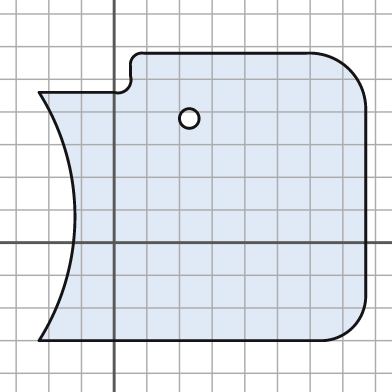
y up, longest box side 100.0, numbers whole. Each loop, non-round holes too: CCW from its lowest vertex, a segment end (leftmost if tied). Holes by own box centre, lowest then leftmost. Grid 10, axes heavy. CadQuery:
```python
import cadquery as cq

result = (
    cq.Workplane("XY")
    .moveTo(-23.0, -30.0)
    .lineTo(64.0, -30.0)
    .threePointArc((73.0, -26.0), (77.0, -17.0))
    .lineTo(77.0, 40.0)
    .threePointArc((72.0, 53.0), (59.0, 58.0))
    .lineTo(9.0, 58.0)
    .threePointArc((6.0, 57.0), (5.0, 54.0))
    .lineTo(5.0, 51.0)
    .threePointArc((4.0, 47.0), (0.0, 46.0))
    .lineTo(-23.0, 46.0)
    .threePointArc((-12.0, 8.0), (-23.0, -30.0))
    .close()
    .moveTo(23.0, 38.0)
    .circle(3.0)
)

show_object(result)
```